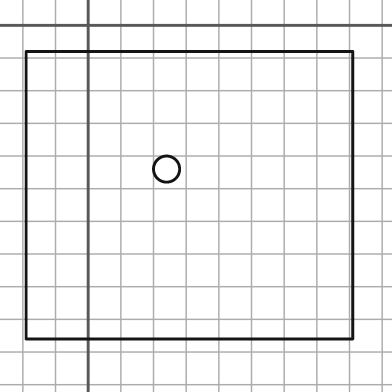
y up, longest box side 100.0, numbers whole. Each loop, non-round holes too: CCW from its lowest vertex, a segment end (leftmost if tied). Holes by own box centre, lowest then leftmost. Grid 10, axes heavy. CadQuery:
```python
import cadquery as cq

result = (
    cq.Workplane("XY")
    .moveTo(-19.0, -96.0)
    .lineTo(81.0, -96.0)
    .lineTo(81.0, -8.0)
    .lineTo(-19.0, -8.0)
    .close()
    .moveTo(24.0, -44.0)
    .circle(4.0)
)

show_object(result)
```